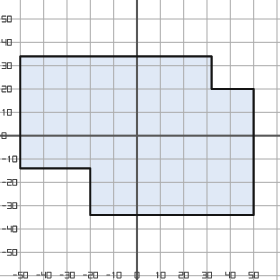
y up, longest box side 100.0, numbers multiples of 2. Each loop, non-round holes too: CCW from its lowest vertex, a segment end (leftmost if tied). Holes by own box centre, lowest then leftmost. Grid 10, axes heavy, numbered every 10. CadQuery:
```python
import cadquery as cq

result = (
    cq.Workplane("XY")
    .moveTo(-20.0, -34.0)
    .lineTo(50.0, -34.0)
    .lineTo(50.0, 20.0)
    .lineTo(32.0, 20.0)
    .lineTo(32.0, 34.0)
    .lineTo(-50.0, 34.0)
    .lineTo(-50.0, -14.0)
    .lineTo(-20.0, -14.0)
    .close()
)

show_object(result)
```